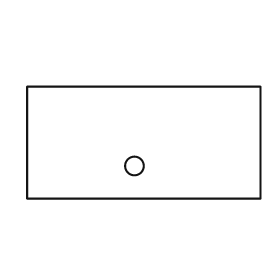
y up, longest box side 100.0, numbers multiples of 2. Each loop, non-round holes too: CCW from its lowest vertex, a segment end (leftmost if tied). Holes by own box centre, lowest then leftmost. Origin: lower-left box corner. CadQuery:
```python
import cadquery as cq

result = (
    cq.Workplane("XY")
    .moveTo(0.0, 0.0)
    .lineTo(100.0, 0.0)
    .lineTo(100.0, 48.0)
    .lineTo(0.0, 48.0)
    .close()
    .moveTo(46.0, 14.0)
    .circle(4.0)
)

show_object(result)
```